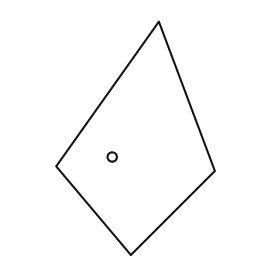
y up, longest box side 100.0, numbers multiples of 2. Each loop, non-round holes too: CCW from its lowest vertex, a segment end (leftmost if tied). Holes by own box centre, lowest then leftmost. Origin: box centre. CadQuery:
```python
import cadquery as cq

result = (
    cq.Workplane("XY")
    .moveTo(-2.0, -50.0)
    .lineTo(34.0, -14.0)
    .lineTo(10.0, 50.0)
    .lineTo(-34.0, -12.0)
    .close()
    .moveTo(-10.0, -8.0)
    .circle(2.0)
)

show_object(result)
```